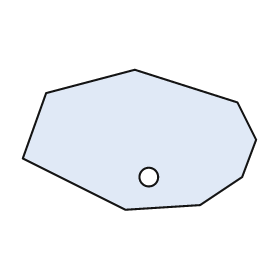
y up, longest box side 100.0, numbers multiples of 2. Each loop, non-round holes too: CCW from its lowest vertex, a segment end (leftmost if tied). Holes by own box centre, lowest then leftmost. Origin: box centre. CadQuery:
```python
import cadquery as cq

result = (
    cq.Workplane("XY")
    .moveTo(-6.0, -30.0)
    .lineTo(26.0, -28.0)
    .lineTo(44.0, -16.0)
    .lineTo(50.0, 0.0)
    .lineTo(42.0, 16.0)
    .lineTo(-2.0, 30.0)
    .lineTo(-40.0, 20.0)
    .lineTo(-50.0, -8.0)
    .close()
    .moveTo(4.0, -16.0)
    .circle(4.0)
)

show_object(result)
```